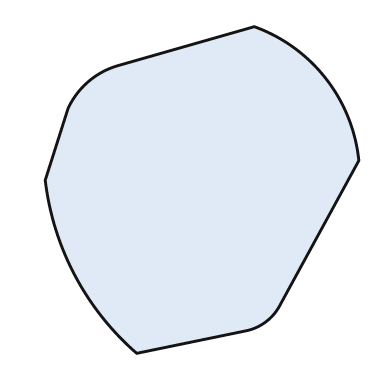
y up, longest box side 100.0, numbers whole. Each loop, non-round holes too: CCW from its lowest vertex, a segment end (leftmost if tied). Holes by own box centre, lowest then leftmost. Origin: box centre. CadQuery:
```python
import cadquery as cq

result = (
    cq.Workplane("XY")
    .moveTo(-20.0, -50.0)
    .lineTo(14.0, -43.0)
    .threePointArc((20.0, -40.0), (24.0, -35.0))
    .lineTo(48.0, 9.0)
    .threePointArc((38.0, 34.0), (16.0, 50.0))
    .lineTo(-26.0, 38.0)
    .threePointArc((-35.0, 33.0), (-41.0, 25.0))
    .lineTo(-48.0, 3.0)
    .threePointArc((-39.0, -26.0), (-20.0, -50.0))
    .close()
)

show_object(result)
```